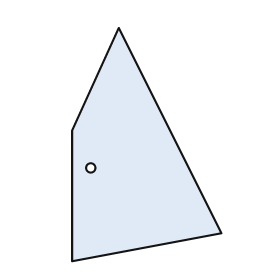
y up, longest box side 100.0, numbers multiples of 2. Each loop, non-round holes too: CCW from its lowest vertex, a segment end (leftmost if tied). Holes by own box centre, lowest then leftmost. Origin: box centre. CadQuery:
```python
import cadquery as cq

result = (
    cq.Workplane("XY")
    .moveTo(-32.0, -50.0)
    .lineTo(32.0, -38.0)
    .lineTo(-12.0, 50.0)
    .lineTo(-32.0, 6.0)
    .close()
    .moveTo(-24.0, -10.0)
    .circle(2.0)
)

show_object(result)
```